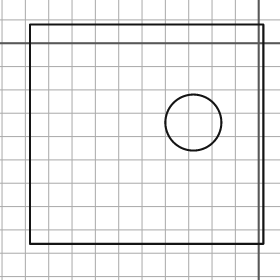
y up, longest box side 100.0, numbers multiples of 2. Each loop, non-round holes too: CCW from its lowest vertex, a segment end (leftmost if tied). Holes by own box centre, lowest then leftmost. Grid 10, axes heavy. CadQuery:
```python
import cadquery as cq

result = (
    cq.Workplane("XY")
    .moveTo(-98.0, -86.0)
    .lineTo(2.0, -86.0)
    .lineTo(2.0, 8.0)
    .lineTo(-98.0, 8.0)
    .close()
    .moveTo(-28.0, -34.0)
    .circle(12.0)
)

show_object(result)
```